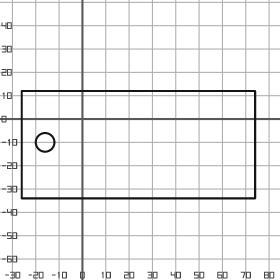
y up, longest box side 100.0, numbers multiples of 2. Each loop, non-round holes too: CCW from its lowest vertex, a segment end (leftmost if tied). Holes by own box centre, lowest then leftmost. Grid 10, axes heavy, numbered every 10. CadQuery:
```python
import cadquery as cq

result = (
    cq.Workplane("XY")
    .moveTo(-26.0, -34.0)
    .lineTo(74.0, -34.0)
    .lineTo(74.0, 12.0)
    .lineTo(-26.0, 12.0)
    .close()
    .moveTo(-16.0, -10.0)
    .circle(4.0)
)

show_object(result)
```